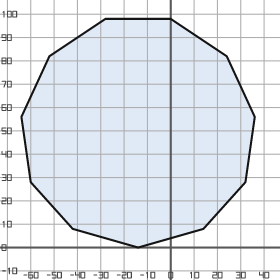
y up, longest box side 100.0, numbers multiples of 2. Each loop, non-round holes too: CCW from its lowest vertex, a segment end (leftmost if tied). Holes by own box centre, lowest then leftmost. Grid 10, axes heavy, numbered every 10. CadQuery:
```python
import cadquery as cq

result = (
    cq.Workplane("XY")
    .moveTo(-14.0, 0.0)
    .lineTo(14.0, 8.0)
    .lineTo(32.0, 28.0)
    .lineTo(36.0, 56.0)
    .lineTo(24.0, 82.0)
    .lineTo(0.0, 98.0)
    .lineTo(-28.0, 98.0)
    .lineTo(-52.0, 82.0)
    .lineTo(-64.0, 56.0)
    .lineTo(-60.0, 28.0)
    .lineTo(-42.0, 8.0)
    .close()
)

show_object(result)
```